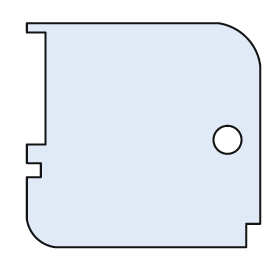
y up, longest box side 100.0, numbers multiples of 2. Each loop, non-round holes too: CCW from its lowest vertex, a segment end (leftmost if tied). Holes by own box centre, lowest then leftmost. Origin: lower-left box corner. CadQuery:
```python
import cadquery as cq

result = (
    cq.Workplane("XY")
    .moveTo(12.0, 0.0)
    .lineTo(94.0, 0.0)
    .lineTo(94.0, 10.0)
    .lineTo(100.0, 10.0)
    .lineTo(100.0, 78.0)
    .threePointArc((94.0, 90.0), (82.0, 96.0))
    .lineTo(0.0, 96.0)
    .lineTo(0.0, 92.0)
    .lineTo(8.0, 92.0)
    .lineTo(8.0, 44.0)
    .lineTo(0.0, 44.0)
    .lineTo(0.0, 36.0)
    .lineTo(6.0, 36.0)
    .lineTo(6.0, 30.0)
    .lineTo(0.0, 30.0)
    .lineTo(0.0, 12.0)
    .threePointArc((4.0, 4.0), (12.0, 0.0))
    .close()
    .moveTo(86.0, 46.0)
    .circle(6.0)
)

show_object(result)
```